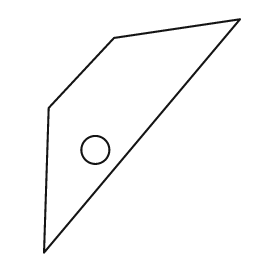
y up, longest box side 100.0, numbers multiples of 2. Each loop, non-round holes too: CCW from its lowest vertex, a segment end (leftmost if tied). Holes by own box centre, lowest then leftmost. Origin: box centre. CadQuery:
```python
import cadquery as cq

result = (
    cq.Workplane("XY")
    .moveTo(-42.0, -50.0)
    .lineTo(42.0, 50.0)
    .lineTo(-12.0, 42.0)
    .lineTo(-40.0, 12.0)
    .close()
    .moveTo(-20.0, -6.0)
    .circle(6.0)
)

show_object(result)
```